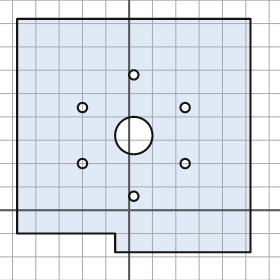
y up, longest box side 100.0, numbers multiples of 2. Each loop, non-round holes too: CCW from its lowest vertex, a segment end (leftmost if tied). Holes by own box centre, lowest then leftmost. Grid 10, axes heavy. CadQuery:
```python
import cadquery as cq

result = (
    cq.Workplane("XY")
    .moveTo(-6.0, -18.0)
    .lineTo(52.0, -18.0)
    .lineTo(52.0, 82.0)
    .lineTo(-48.0, 82.0)
    .lineTo(-48.0, -10.0)
    .lineTo(-6.0, -10.0)
    .close()
    .moveTo(2.0, 6.0)
    .circle(2.0)
    .moveTo(-20.0, 20.0)
    .circle(2.0)
    .moveTo(24.0, 20.0)
    .circle(2.0)
    .moveTo(2.0, 32.0)
    .circle(8.0)
    .moveTo(-20.0, 44.0)
    .circle(2.0)
    .moveTo(24.0, 44.0)
    .circle(2.0)
    .moveTo(2.0, 58.0)
    .circle(2.0)
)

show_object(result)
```